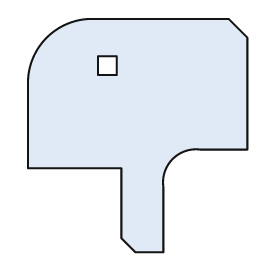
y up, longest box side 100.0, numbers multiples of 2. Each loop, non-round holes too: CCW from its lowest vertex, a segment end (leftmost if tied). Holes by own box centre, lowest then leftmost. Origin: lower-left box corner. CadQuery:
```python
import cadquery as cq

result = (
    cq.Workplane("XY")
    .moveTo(46.0, 0.0)
    .lineTo(58.0, 0.0)
    .lineTo(58.0, 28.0)
    .threePointArc((62.0, 40.0), (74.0, 44.0))
    .lineTo(94.0, 44.0)
    .lineTo(94.0, 92.0)
    .lineTo(86.0, 100.0)
    .lineTo(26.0, 100.0)
    .threePointArc((8.0, 92.0), (0.0, 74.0))
    .lineTo(0.0, 36.0)
    .lineTo(40.0, 36.0)
    .lineTo(40.0, 6.0)
    .close()
    .moveTo(30.0, 76.0)
    .lineTo(38.0, 76.0)
    .lineTo(38.0, 84.0)
    .lineTo(30.0, 84.0)
    .close()
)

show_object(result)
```